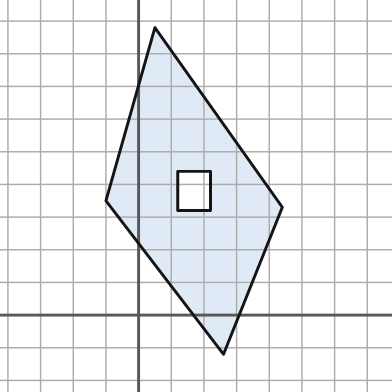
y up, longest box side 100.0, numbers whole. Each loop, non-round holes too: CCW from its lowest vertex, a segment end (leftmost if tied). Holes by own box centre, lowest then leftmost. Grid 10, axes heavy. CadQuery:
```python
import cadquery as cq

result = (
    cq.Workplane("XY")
    .moveTo(26.0, -12.0)
    .lineTo(44.0, 33.0)
    .lineTo(5.0, 88.0)
    .lineTo(-10.0, 35.0)
    .close()
    .moveTo(12.0, 32.0)
    .lineTo(22.0, 32.0)
    .lineTo(22.0, 44.0)
    .lineTo(12.0, 44.0)
    .close()
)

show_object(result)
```